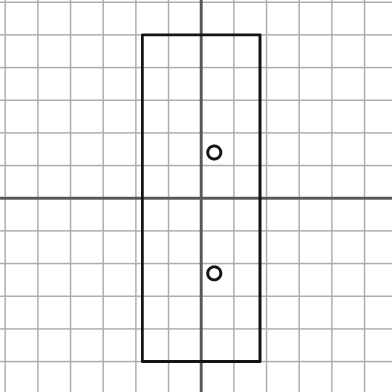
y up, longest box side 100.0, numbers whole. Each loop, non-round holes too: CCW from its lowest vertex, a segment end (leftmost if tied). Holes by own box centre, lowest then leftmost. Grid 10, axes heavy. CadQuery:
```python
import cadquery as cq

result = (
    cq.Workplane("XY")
    .moveTo(-18.0, -50.0)
    .lineTo(18.0, -50.0)
    .lineTo(18.0, 50.0)
    .lineTo(-18.0, 50.0)
    .close()
    .moveTo(4.0, -23.0)
    .circle(2.0)
    .moveTo(4.0, 14.0)
    .circle(2.0)
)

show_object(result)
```